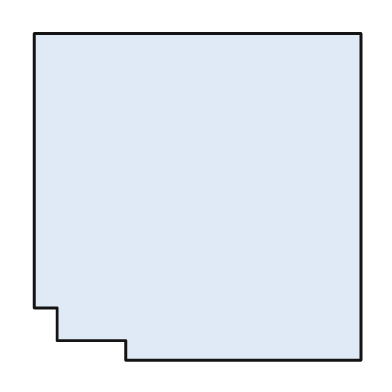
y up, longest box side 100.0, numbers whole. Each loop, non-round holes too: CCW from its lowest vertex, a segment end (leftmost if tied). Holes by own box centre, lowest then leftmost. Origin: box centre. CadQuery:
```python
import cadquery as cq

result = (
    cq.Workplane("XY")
    .moveTo(-22.0, -50.0)
    .lineTo(50.0, -50.0)
    .lineTo(50.0, 50.0)
    .lineTo(-50.0, 50.0)
    .lineTo(-50.0, -34.0)
    .lineTo(-43.0, -34.0)
    .lineTo(-43.0, -44.0)
    .lineTo(-22.0, -44.0)
    .close()
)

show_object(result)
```